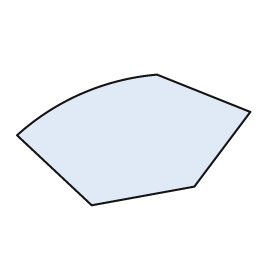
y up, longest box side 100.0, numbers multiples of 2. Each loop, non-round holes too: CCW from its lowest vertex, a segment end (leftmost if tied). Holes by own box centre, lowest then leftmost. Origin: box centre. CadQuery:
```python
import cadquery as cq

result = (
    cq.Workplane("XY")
    .moveTo(-18.0, -28.0)
    .lineTo(26.0, -20.0)
    .lineTo(50.0, 12.0)
    .lineTo(10.0, 28.0)
    .threePointArc((-22.0, 20.0), (-50.0, 2.0))
    .close()
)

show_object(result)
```